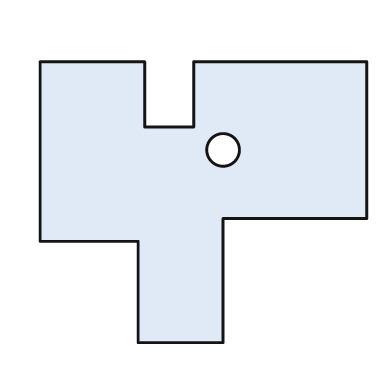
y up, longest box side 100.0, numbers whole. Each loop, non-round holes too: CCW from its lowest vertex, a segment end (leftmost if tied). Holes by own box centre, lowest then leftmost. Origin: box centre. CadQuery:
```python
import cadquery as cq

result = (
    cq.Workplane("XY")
    .moveTo(-20.0, -43.0)
    .lineTo(6.0, -43.0)
    .lineTo(6.0, -5.0)
    .lineTo(50.0, -5.0)
    .lineTo(50.0, 43.0)
    .lineTo(-3.0, 43.0)
    .lineTo(-3.0, 23.0)
    .lineTo(-18.0, 23.0)
    .lineTo(-18.0, 43.0)
    .lineTo(-50.0, 43.0)
    .lineTo(-50.0, -12.0)
    .lineTo(-20.0, -12.0)
    .close()
    .moveTo(6.0, 16.0)
    .circle(5.0)
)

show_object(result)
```